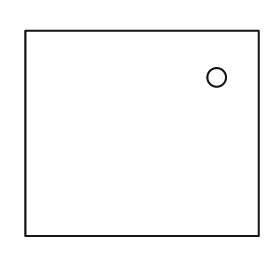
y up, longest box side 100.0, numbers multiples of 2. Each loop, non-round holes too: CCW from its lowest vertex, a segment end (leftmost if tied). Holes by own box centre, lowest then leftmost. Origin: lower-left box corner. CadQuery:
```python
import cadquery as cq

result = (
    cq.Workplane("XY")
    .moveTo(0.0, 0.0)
    .lineTo(100.0, 0.0)
    .lineTo(100.0, 88.0)
    .lineTo(0.0, 88.0)
    .close()
    .moveTo(82.0, 68.0)
    .circle(4.0)
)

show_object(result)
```